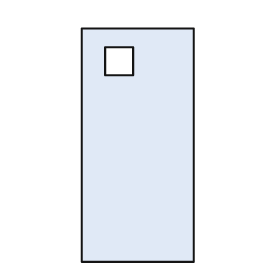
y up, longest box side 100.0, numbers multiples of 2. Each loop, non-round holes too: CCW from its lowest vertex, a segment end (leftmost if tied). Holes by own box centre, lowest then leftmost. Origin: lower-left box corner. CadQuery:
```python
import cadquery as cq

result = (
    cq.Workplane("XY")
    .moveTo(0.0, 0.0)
    .lineTo(48.0, 0.0)
    .lineTo(48.0, 100.0)
    .lineTo(0.0, 100.0)
    .close()
    .moveTo(10.0, 80.0)
    .lineTo(22.0, 80.0)
    .lineTo(22.0, 92.0)
    .lineTo(10.0, 92.0)
    .close()
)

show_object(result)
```